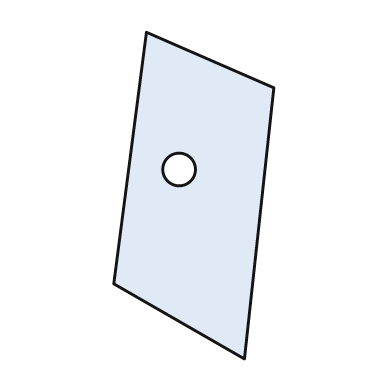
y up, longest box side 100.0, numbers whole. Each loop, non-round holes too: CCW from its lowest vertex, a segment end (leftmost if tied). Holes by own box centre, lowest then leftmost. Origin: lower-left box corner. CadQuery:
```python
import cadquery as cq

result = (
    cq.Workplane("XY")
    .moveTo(40.0, 0.0)
    .lineTo(49.0, 83.0)
    .lineTo(10.0, 100.0)
    .lineTo(0.0, 23.0)
    .close()
    .moveTo(20.0, 58.0)
    .circle(5.0)
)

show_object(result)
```